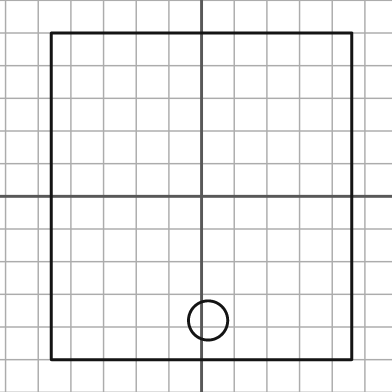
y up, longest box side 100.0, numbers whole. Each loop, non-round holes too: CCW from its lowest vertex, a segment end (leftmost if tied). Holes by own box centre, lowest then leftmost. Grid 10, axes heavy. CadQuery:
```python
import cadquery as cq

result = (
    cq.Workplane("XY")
    .moveTo(-46.0, -50.0)
    .lineTo(46.0, -50.0)
    .lineTo(46.0, 50.0)
    .lineTo(-46.0, 50.0)
    .close()
    .moveTo(2.0, -38.0)
    .circle(6.0)
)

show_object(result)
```